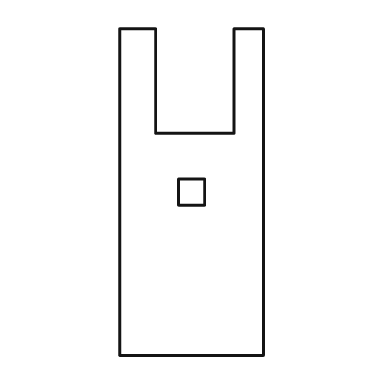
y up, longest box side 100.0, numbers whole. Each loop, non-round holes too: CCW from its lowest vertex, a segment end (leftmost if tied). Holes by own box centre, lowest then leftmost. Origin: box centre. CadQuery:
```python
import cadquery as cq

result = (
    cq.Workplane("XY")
    .moveTo(-22.0, -50.0)
    .lineTo(22.0, -50.0)
    .lineTo(22.0, 50.0)
    .lineTo(13.0, 50.0)
    .lineTo(13.0, 18.0)
    .lineTo(-11.0, 18.0)
    .lineTo(-11.0, 50.0)
    .lineTo(-22.0, 50.0)
    .close()
    .moveTo(-4.0, -4.0)
    .lineTo(4.0, -4.0)
    .lineTo(4.0, 4.0)
    .lineTo(-4.0, 4.0)
    .close()
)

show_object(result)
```